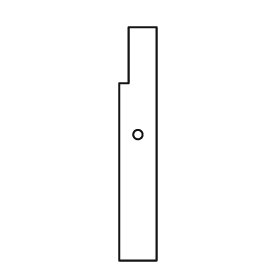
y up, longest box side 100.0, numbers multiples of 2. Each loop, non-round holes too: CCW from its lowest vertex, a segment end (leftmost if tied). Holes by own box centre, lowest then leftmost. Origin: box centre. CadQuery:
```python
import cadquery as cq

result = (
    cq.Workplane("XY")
    .moveTo(-8.0, -50.0)
    .lineTo(8.0, -50.0)
    .lineTo(8.0, 50.0)
    .lineTo(-4.0, 50.0)
    .lineTo(-4.0, 26.0)
    .lineTo(-8.0, 26.0)
    .close()
    .moveTo(0.0, 4.0)
    .circle(2.0)
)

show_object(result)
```